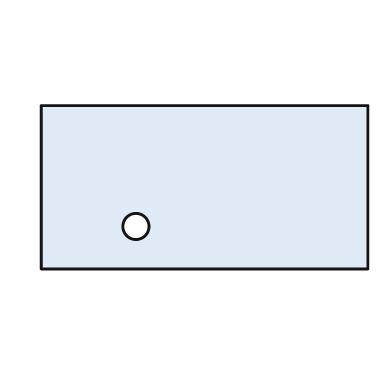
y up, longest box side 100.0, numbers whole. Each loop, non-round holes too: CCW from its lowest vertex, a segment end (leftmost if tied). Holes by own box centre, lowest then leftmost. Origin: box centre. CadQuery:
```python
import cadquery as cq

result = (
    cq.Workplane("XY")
    .moveTo(-50.0, -25.0)
    .lineTo(50.0, -25.0)
    .lineTo(50.0, 25.0)
    .lineTo(-50.0, 25.0)
    .close()
    .moveTo(-21.0, -12.0)
    .circle(4.0)
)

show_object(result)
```